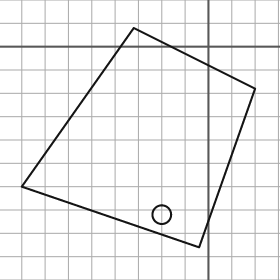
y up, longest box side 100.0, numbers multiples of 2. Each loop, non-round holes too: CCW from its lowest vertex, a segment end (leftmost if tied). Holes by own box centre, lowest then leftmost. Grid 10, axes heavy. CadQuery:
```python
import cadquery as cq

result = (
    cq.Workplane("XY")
    .moveTo(-4.0, -86.0)
    .lineTo(20.0, -18.0)
    .lineTo(-32.0, 8.0)
    .lineTo(-80.0, -60.0)
    .close()
    .moveTo(-20.0, -72.0)
    .circle(4.0)
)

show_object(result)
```